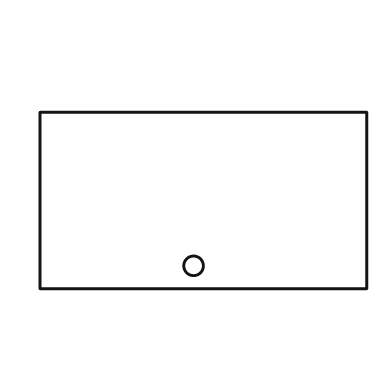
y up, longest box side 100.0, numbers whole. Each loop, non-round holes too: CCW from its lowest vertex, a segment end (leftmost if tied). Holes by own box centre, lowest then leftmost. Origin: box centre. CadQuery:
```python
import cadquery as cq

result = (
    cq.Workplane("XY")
    .moveTo(-50.0, -27.0)
    .lineTo(50.0, -27.0)
    .lineTo(50.0, 27.0)
    .lineTo(-50.0, 27.0)
    .close()
    .moveTo(-3.0, -20.0)
    .circle(3.0)
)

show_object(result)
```